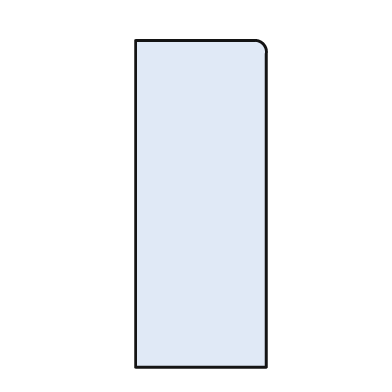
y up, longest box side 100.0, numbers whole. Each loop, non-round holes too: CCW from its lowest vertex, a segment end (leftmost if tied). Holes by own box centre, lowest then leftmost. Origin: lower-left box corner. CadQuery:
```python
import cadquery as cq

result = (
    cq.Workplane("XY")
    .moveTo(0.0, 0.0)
    .lineTo(40.0, 0.0)
    .lineTo(40.0, 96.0)
    .threePointArc((39.0, 99.0), (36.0, 100.0))
    .lineTo(0.0, 100.0)
    .close()
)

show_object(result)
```